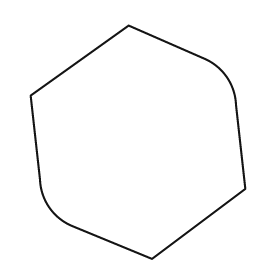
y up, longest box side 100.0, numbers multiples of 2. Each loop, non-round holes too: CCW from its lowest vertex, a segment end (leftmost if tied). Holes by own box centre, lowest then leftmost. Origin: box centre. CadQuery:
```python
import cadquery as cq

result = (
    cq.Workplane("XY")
    .moveTo(6.0, -50.0)
    .lineTo(46.0, -20.0)
    .lineTo(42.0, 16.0)
    .threePointArc((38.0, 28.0), (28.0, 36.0))
    .lineTo(-4.0, 50.0)
    .lineTo(-46.0, 20.0)
    .lineTo(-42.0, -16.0)
    .threePointArc((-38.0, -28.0), (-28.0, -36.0))
    .close()
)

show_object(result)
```